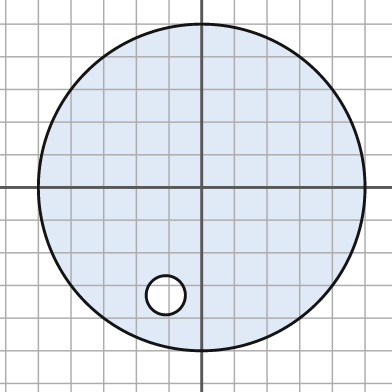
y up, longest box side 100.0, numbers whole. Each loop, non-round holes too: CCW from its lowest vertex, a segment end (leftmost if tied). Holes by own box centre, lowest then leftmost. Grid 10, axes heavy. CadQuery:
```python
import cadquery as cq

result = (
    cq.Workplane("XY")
    .moveTo(0.0, 0.0)
    .circle(50.0)
    .moveTo(-11.0, -33.0)
    .circle(6.0)
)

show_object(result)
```